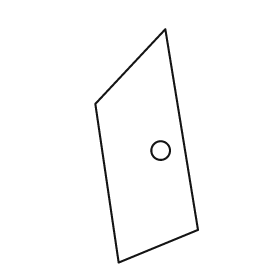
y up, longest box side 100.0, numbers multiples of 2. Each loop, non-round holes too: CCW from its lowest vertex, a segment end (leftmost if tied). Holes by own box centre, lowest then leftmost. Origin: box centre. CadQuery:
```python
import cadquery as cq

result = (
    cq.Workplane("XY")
    .moveTo(-12.0, -50.0)
    .lineTo(22.0, -36.0)
    .lineTo(8.0, 50.0)
    .lineTo(-22.0, 18.0)
    .close()
    .moveTo(6.0, -2.0)
    .circle(4.0)
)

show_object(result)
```